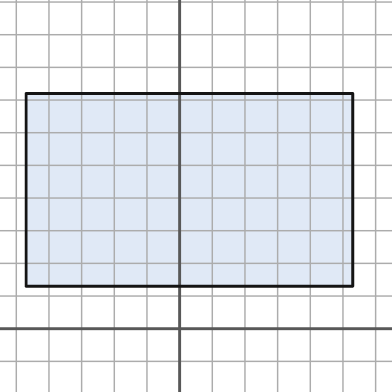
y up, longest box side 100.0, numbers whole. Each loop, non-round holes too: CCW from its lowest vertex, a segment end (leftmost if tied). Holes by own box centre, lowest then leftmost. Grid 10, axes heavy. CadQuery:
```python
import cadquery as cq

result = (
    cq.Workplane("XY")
    .moveTo(-47.0, 13.0)
    .lineTo(53.0, 13.0)
    .lineTo(53.0, 72.0)
    .lineTo(-47.0, 72.0)
    .close()
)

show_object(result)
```